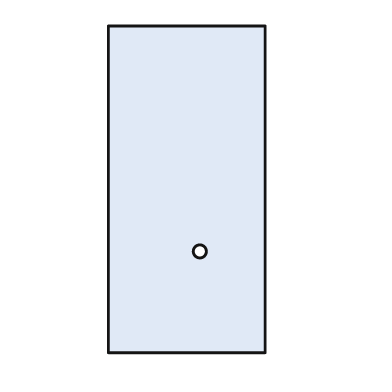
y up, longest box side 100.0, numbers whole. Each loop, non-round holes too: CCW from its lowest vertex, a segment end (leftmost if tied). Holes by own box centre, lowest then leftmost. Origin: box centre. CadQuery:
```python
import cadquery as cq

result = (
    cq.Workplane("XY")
    .moveTo(-24.0, -50.0)
    .lineTo(24.0, -50.0)
    .lineTo(24.0, 50.0)
    .lineTo(-24.0, 50.0)
    .close()
    .moveTo(4.0, -19.0)
    .circle(2.0)
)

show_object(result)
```